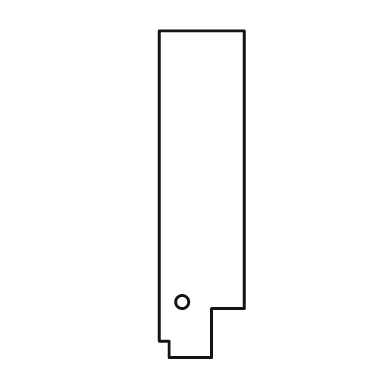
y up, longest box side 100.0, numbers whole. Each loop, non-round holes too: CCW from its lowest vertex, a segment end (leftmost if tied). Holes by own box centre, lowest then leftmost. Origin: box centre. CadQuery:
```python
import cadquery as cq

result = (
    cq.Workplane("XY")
    .moveTo(-10.0, -50.0)
    .lineTo(3.0, -50.0)
    .lineTo(3.0, -35.0)
    .lineTo(13.0, -35.0)
    .lineTo(13.0, 50.0)
    .lineTo(-13.0, 50.0)
    .lineTo(-13.0, -45.0)
    .lineTo(-10.0, -45.0)
    .close()
    .moveTo(-6.0, -33.0)
    .circle(2.0)
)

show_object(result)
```